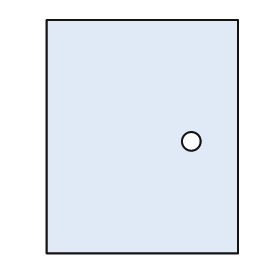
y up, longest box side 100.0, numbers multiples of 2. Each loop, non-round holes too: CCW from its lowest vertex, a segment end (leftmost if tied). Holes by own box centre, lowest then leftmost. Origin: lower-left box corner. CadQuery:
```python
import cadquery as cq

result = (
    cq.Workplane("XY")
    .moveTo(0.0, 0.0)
    .lineTo(82.0, 0.0)
    .lineTo(82.0, 100.0)
    .lineTo(0.0, 100.0)
    .close()
    .moveTo(62.0, 48.0)
    .circle(4.0)
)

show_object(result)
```